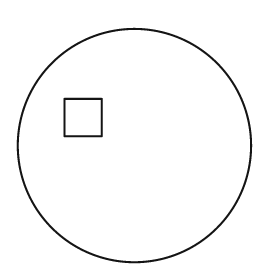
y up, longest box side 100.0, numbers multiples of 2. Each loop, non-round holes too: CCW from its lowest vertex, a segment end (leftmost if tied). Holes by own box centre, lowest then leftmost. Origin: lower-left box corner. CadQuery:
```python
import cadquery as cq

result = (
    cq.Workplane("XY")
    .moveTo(50.0, 50.0)
    .circle(50.0)
    .moveTo(20.0, 54.0)
    .lineTo(36.0, 54.0)
    .lineTo(36.0, 70.0)
    .lineTo(20.0, 70.0)
    .close()
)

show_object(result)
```